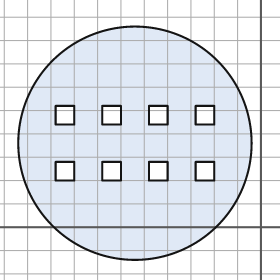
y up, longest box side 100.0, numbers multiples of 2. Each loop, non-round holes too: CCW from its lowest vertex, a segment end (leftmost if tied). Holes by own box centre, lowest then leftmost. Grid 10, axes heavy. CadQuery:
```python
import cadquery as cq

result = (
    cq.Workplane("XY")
    .moveTo(-54.0, 36.0)
    .circle(50.0)
    .moveTo(-88.0, 20.0)
    .lineTo(-80.0, 20.0)
    .lineTo(-80.0, 28.0)
    .lineTo(-88.0, 28.0)
    .close()
    .moveTo(-68.0, 20.0)
    .lineTo(-60.0, 20.0)
    .lineTo(-60.0, 28.0)
    .lineTo(-68.0, 28.0)
    .close()
    .moveTo(-48.0, 20.0)
    .lineTo(-40.0, 20.0)
    .lineTo(-40.0, 28.0)
    .lineTo(-48.0, 28.0)
    .close()
    .moveTo(-28.0, 20.0)
    .lineTo(-20.0, 20.0)
    .lineTo(-20.0, 28.0)
    .lineTo(-28.0, 28.0)
    .close()
    .moveTo(-88.0, 44.0)
    .lineTo(-80.0, 44.0)
    .lineTo(-80.0, 52.0)
    .lineTo(-88.0, 52.0)
    .close()
    .moveTo(-68.0, 44.0)
    .lineTo(-60.0, 44.0)
    .lineTo(-60.0, 52.0)
    .lineTo(-68.0, 52.0)
    .close()
    .moveTo(-48.0, 44.0)
    .lineTo(-40.0, 44.0)
    .lineTo(-40.0, 52.0)
    .lineTo(-48.0, 52.0)
    .close()
    .moveTo(-28.0, 44.0)
    .lineTo(-20.0, 44.0)
    .lineTo(-20.0, 52.0)
    .lineTo(-28.0, 52.0)
    .close()
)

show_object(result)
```